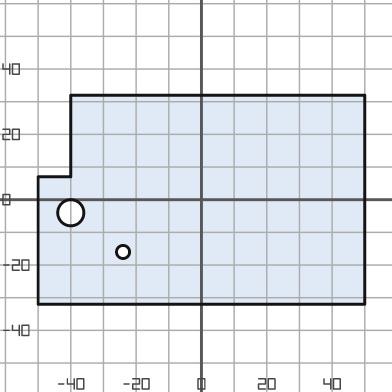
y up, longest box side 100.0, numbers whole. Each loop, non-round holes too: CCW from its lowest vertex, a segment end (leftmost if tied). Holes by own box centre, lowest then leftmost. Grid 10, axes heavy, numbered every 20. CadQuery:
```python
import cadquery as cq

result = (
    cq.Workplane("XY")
    .moveTo(-50.0, -32.0)
    .lineTo(50.0, -32.0)
    .lineTo(50.0, 32.0)
    .lineTo(-40.0, 32.0)
    .lineTo(-40.0, 7.0)
    .lineTo(-50.0, 7.0)
    .close()
    .moveTo(-24.0, -16.0)
    .circle(2.0)
    .moveTo(-40.0, -4.0)
    .circle(4.0)
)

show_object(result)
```